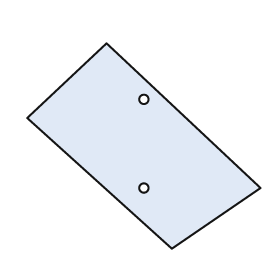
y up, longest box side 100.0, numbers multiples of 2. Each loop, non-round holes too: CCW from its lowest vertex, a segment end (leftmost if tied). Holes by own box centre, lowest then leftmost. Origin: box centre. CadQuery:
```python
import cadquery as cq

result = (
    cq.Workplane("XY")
    .moveTo(12.0, -44.0)
    .lineTo(50.0, -18.0)
    .lineTo(-16.0, 44.0)
    .lineTo(-50.0, 12.0)
    .close()
    .moveTo(0.0, -18.0)
    .circle(2.0)
    .moveTo(0.0, 20.0)
    .circle(2.0)
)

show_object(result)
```